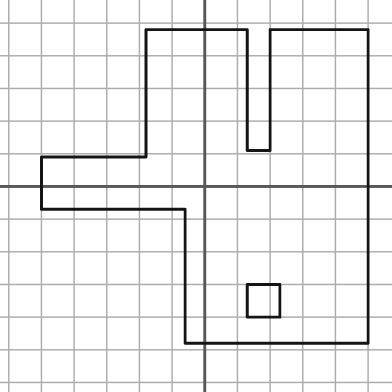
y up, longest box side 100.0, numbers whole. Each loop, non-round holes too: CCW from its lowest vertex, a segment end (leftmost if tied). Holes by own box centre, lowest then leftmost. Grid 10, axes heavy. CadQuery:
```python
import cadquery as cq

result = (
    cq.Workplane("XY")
    .moveTo(-6.0, -48.0)
    .lineTo(50.0, -48.0)
    .lineTo(50.0, 48.0)
    .lineTo(20.0, 48.0)
    .lineTo(20.0, 11.0)
    .lineTo(13.0, 11.0)
    .lineTo(13.0, 48.0)
    .lineTo(-18.0, 48.0)
    .lineTo(-18.0, 9.0)
    .lineTo(-50.0, 9.0)
    .lineTo(-50.0, -7.0)
    .lineTo(-6.0, -7.0)
    .close()
    .moveTo(13.0, -40.0)
    .lineTo(23.0, -40.0)
    .lineTo(23.0, -30.0)
    .lineTo(13.0, -30.0)
    .close()
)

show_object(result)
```